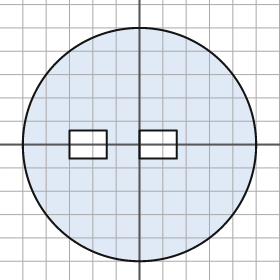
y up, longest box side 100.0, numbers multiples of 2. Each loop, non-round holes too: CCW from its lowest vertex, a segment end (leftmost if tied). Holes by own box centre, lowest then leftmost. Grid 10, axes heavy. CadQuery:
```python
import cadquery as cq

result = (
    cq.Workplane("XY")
    .moveTo(0.0, 0.0)
    .circle(50.0)
    .moveTo(-30.0, -6.0)
    .lineTo(-14.0, -6.0)
    .lineTo(-14.0, 6.0)
    .lineTo(-30.0, 6.0)
    .close()
    .moveTo(0.0, -6.0)
    .lineTo(16.0, -6.0)
    .lineTo(16.0, 6.0)
    .lineTo(0.0, 6.0)
    .close()
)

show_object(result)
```